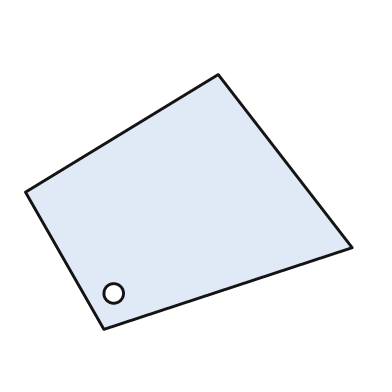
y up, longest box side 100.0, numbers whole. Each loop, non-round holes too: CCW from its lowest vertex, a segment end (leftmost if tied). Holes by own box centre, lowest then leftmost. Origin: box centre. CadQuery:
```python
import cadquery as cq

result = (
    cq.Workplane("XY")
    .moveTo(-26.0, -39.0)
    .lineTo(50.0, -14.0)
    .lineTo(9.0, 39.0)
    .lineTo(-50.0, 3.0)
    .close()
    .moveTo(-23.0, -28.0)
    .circle(3.0)
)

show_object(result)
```